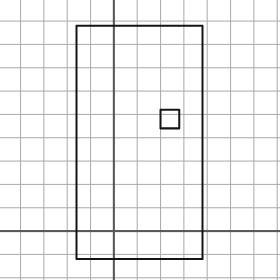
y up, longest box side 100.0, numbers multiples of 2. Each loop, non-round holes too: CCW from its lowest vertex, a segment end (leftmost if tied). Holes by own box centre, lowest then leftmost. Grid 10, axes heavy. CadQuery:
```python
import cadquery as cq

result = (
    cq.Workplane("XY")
    .moveTo(-16.0, -12.0)
    .lineTo(38.0, -12.0)
    .lineTo(38.0, 88.0)
    .lineTo(-16.0, 88.0)
    .close()
    .moveTo(20.0, 44.0)
    .lineTo(28.0, 44.0)
    .lineTo(28.0, 52.0)
    .lineTo(20.0, 52.0)
    .close()
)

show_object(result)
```